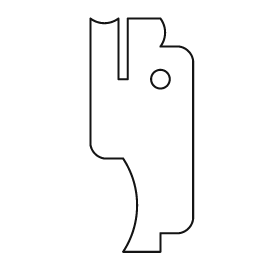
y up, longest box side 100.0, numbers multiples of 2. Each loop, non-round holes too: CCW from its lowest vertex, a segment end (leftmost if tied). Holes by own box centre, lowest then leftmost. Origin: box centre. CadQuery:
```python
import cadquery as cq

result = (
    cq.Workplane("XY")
    .moveTo(-8.0, -50.0)
    .lineTo(8.0, -50.0)
    .lineTo(8.0, -42.0)
    .lineTo(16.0, -42.0)
    .threePointArc((20.0, -40.0), (22.0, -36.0))
    .lineTo(22.0, 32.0)
    .threePointArc((20.0, 36.0), (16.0, 38.0))
    .lineTo(8.0, 38.0)
    .threePointArc((10.0, 44.0), (8.0, 50.0))
    .lineTo(-6.0, 50.0)
    .lineTo(-6.0, 24.0)
    .lineTo(-10.0, 24.0)
    .lineTo(-10.0, 50.0)
    .threePointArc((-16.0, 48.0), (-22.0, 50.0))
    .lineTo(-22.0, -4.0)
    .threePointArc((-20.0, -8.0), (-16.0, -10.0))
    .lineTo(-8.0, -10.0)
    .threePointArc((-2.0, -30.0), (-8.0, -50.0))
    .close()
    .moveTo(8.0, 24.0)
    .circle(4.0)
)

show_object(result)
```